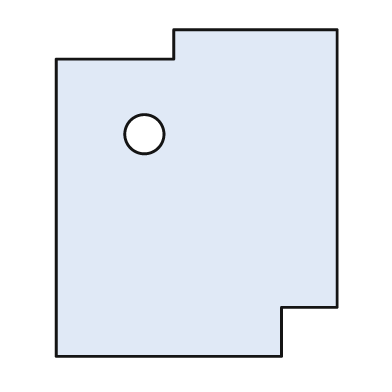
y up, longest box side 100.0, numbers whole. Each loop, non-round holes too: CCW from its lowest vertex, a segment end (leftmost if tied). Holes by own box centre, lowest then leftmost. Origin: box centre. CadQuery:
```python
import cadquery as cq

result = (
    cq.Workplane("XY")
    .moveTo(-43.0, -50.0)
    .lineTo(26.0, -50.0)
    .lineTo(26.0, -35.0)
    .lineTo(43.0, -35.0)
    .lineTo(43.0, 50.0)
    .lineTo(-7.0, 50.0)
    .lineTo(-7.0, 41.0)
    .lineTo(-43.0, 41.0)
    .close()
    .moveTo(-16.0, 18.0)
    .circle(6.0)
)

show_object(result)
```